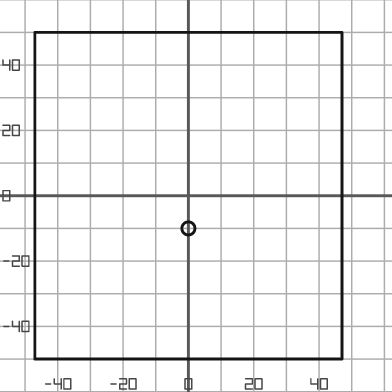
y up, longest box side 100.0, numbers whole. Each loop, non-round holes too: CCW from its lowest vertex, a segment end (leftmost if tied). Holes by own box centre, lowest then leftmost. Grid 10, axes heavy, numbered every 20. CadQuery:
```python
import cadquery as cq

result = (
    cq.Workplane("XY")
    .moveTo(-47.0, -50.0)
    .lineTo(47.0, -50.0)
    .lineTo(47.0, 50.0)
    .lineTo(-47.0, 50.0)
    .close()
    .moveTo(0.0, -10.0)
    .circle(2.0)
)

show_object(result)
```